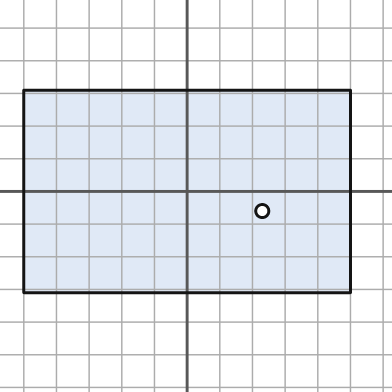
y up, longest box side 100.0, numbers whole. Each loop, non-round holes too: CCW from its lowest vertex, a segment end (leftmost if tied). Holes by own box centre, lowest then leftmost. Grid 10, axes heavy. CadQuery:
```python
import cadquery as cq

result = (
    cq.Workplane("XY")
    .moveTo(-50.0, -31.0)
    .lineTo(50.0, -31.0)
    .lineTo(50.0, 31.0)
    .lineTo(-50.0, 31.0)
    .close()
    .moveTo(23.0, -6.0)
    .circle(2.0)
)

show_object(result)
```